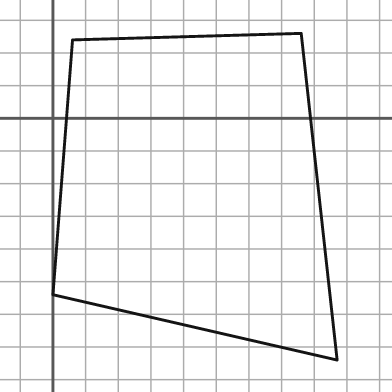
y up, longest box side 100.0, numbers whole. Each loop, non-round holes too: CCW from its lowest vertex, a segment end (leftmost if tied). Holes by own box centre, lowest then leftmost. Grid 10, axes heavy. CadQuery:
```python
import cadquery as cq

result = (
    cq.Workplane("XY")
    .moveTo(87.0, -74.0)
    .lineTo(76.0, 26.0)
    .lineTo(6.0, 24.0)
    .lineTo(0.0, -54.0)
    .close()
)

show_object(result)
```